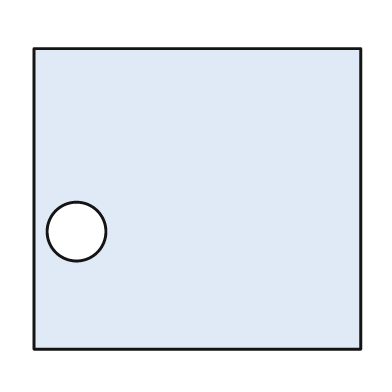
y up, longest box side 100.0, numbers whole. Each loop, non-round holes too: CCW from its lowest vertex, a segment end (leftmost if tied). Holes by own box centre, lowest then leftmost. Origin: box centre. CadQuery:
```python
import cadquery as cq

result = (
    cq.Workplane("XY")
    .moveTo(-50.0, -46.0)
    .lineTo(50.0, -46.0)
    .lineTo(50.0, 46.0)
    .lineTo(-50.0, 46.0)
    .close()
    .moveTo(-37.0, -10.0)
    .circle(9.0)
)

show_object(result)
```